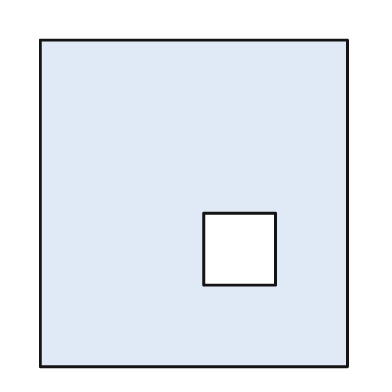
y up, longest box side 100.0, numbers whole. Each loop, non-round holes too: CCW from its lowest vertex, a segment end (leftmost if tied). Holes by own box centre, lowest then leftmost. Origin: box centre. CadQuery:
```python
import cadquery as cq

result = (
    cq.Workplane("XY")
    .moveTo(-47.0, -50.0)
    .lineTo(47.0, -50.0)
    .lineTo(47.0, 50.0)
    .lineTo(-47.0, 50.0)
    .close()
    .moveTo(3.0, -25.0)
    .lineTo(25.0, -25.0)
    .lineTo(25.0, -3.0)
    .lineTo(3.0, -3.0)
    .close()
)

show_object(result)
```